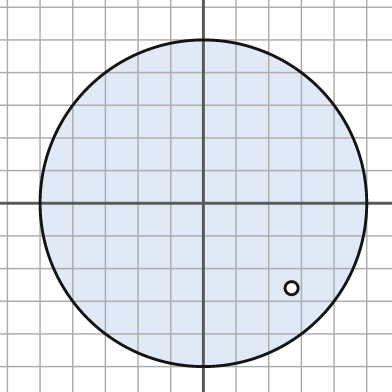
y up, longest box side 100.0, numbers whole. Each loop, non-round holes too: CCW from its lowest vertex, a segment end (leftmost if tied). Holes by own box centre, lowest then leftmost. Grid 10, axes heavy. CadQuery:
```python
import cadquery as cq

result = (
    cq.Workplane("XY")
    .moveTo(0.0, 0.0)
    .circle(50.0)
    .moveTo(27.0, -26.0)
    .circle(2.0)
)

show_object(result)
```